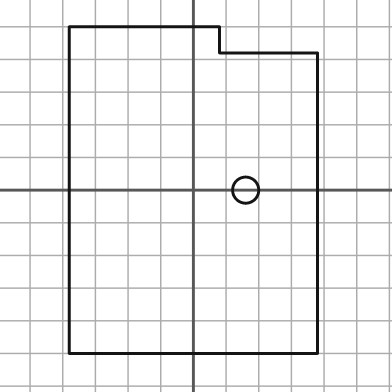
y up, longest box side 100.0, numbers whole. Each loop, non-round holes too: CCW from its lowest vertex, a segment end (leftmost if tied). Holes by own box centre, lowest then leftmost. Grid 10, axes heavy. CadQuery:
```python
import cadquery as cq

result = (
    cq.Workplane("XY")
    .moveTo(-38.0, -50.0)
    .lineTo(38.0, -50.0)
    .lineTo(38.0, 42.0)
    .lineTo(8.0, 42.0)
    .lineTo(8.0, 50.0)
    .lineTo(-38.0, 50.0)
    .close()
    .moveTo(16.0, 0.0)
    .circle(4.0)
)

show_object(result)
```